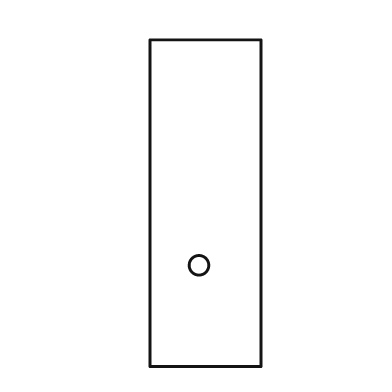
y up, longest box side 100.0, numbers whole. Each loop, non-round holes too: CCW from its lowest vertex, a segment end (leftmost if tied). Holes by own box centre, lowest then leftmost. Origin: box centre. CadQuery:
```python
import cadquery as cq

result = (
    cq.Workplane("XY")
    .moveTo(-17.0, -50.0)
    .lineTo(17.0, -50.0)
    .lineTo(17.0, 50.0)
    .lineTo(-17.0, 50.0)
    .close()
    .moveTo(-2.0, -19.0)
    .circle(3.0)
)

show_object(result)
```